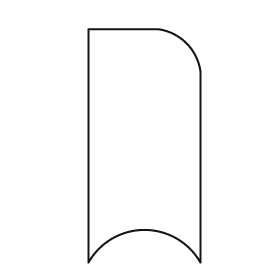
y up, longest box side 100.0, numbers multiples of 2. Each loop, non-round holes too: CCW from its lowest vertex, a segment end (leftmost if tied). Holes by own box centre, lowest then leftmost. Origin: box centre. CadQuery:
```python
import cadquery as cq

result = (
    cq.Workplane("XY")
    .moveTo(-24.0, -50.0)
    .threePointArc((0.0, -36.0), (24.0, -50.0))
    .lineTo(24.0, 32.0)
    .threePointArc((18.0, 44.0), (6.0, 50.0))
    .lineTo(-24.0, 50.0)
    .close()
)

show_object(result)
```